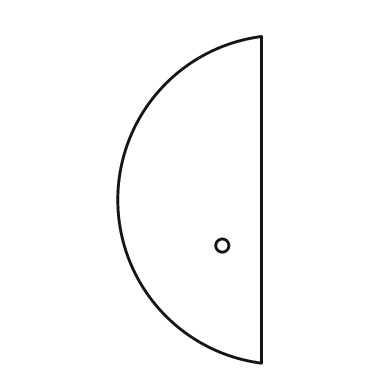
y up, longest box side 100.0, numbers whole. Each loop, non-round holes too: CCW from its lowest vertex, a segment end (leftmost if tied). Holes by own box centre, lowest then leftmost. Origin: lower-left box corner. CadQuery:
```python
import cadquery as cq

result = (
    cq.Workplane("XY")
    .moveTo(44.0, 0.0)
    .lineTo(44.0, 100.0)
    .threePointArc((0.0, 50.0), (44.0, 0.0))
    .close()
    .moveTo(32.0, 36.0)
    .circle(2.0)
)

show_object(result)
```